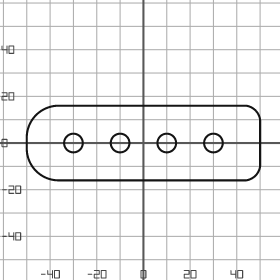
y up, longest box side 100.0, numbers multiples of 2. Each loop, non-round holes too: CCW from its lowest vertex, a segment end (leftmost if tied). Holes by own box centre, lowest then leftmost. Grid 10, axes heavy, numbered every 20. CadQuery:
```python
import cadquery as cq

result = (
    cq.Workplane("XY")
    .moveTo(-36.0, -16.0)
    .lineTo(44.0, -16.0)
    .threePointArc((48.0, -14.0), (50.0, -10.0))
    .lineTo(50.0, 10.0)
    .threePointArc((48.0, 14.0), (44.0, 16.0))
    .lineTo(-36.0, 16.0)
    .threePointArc((-46.0, 12.0), (-50.0, 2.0))
    .lineTo(-50.0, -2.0)
    .threePointArc((-46.0, -12.0), (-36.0, -16.0))
    .close()
    .moveTo(-30.0, 0.0)
    .circle(4.0)
    .moveTo(-10.0, 0.0)
    .circle(4.0)
    .moveTo(10.0, 0.0)
    .circle(4.0)
    .moveTo(30.0, 0.0)
    .circle(4.0)
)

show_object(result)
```